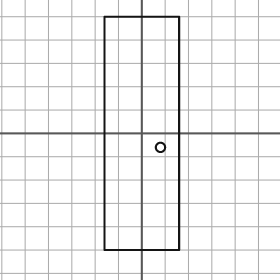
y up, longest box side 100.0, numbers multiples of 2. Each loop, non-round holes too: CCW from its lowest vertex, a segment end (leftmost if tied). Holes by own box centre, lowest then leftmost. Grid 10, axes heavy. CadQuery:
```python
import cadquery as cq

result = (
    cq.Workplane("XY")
    .moveTo(-16.0, -50.0)
    .lineTo(16.0, -50.0)
    .lineTo(16.0, 50.0)
    .lineTo(-16.0, 50.0)
    .close()
    .moveTo(8.0, -6.0)
    .circle(2.0)
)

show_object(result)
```